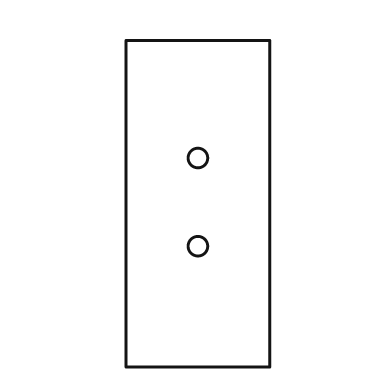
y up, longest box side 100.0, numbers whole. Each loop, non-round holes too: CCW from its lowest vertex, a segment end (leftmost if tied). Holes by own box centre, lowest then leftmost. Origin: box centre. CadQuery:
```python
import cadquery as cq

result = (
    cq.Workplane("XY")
    .moveTo(-22.0, -50.0)
    .lineTo(22.0, -50.0)
    .lineTo(22.0, 50.0)
    .lineTo(-22.0, 50.0)
    .close()
    .moveTo(0.0, -13.0)
    .circle(3.0)
    .moveTo(0.0, 14.0)
    .circle(3.0)
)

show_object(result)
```